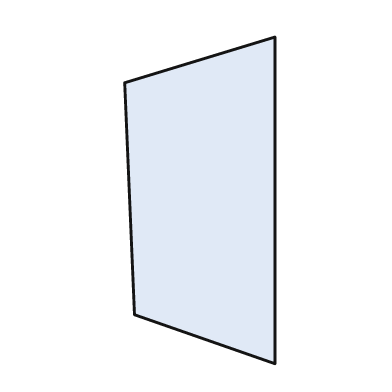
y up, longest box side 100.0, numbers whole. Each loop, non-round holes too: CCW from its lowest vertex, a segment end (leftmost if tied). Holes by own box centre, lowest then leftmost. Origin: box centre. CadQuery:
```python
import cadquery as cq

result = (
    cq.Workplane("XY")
    .moveTo(23.0, -50.0)
    .lineTo(23.0, 50.0)
    .lineTo(-23.0, 36.0)
    .lineTo(-20.0, -35.0)
    .close()
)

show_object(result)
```